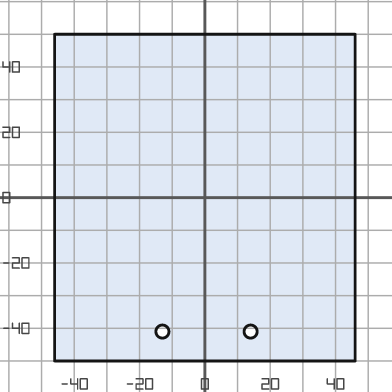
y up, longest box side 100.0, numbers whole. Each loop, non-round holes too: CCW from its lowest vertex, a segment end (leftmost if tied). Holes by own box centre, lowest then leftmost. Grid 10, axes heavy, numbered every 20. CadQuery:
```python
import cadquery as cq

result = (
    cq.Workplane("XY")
    .moveTo(-46.0, -50.0)
    .lineTo(46.0, -50.0)
    .lineTo(46.0, 50.0)
    .lineTo(-46.0, 50.0)
    .close()
    .moveTo(-13.0, -41.0)
    .circle(2.0)
    .moveTo(14.0, -41.0)
    .circle(2.0)
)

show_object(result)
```